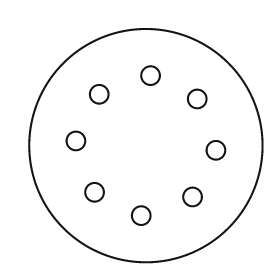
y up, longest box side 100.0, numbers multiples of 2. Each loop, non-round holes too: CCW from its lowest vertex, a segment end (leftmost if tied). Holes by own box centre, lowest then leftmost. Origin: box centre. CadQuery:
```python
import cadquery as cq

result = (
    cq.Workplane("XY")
    .moveTo(0.0, 0.0)
    .circle(50.0)
    .moveTo(-2.0, -30.0)
    .circle(4.0)
    .moveTo(20.0, -22.0)
    .circle(4.0)
    .moveTo(-22.0, -20.0)
    .circle(4.0)
    .moveTo(30.0, -2.0)
    .circle(4.0)
    .moveTo(-30.0, 2.0)
    .circle(4.0)
    .moveTo(22.0, 20.0)
    .circle(4.0)
    .moveTo(-20.0, 22.0)
    .circle(4.0)
    .moveTo(2.0, 30.0)
    .circle(4.0)
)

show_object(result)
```